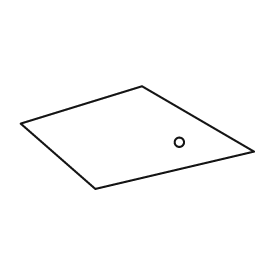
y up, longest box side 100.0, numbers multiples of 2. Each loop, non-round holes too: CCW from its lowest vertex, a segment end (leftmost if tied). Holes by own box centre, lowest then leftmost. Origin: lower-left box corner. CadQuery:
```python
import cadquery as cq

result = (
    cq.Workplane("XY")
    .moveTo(32.0, 0.0)
    .lineTo(100.0, 16.0)
    .lineTo(52.0, 44.0)
    .lineTo(0.0, 28.0)
    .close()
    .moveTo(68.0, 20.0)
    .circle(2.0)
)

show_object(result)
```